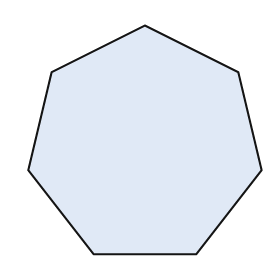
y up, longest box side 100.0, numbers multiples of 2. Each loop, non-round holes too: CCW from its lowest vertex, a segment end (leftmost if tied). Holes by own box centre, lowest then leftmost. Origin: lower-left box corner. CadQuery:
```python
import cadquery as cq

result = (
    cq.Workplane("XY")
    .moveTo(28.0, 0.0)
    .lineTo(72.0, 0.0)
    .lineTo(100.0, 36.0)
    .lineTo(90.0, 78.0)
    .lineTo(50.0, 98.0)
    .lineTo(10.0, 78.0)
    .lineTo(0.0, 36.0)
    .close()
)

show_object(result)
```